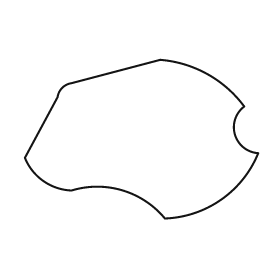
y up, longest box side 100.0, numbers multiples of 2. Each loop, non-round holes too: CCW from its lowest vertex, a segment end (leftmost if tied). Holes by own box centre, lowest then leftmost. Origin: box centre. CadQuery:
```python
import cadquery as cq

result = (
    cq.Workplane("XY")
    .moveTo(10.0, -34.0)
    .threePointArc((34.0, -26.0), (50.0, -6.0))
    .threePointArc((40.0, 2.0), (44.0, 14.0))
    .threePointArc((28.0, 28.0), (8.0, 34.0))
    .lineTo(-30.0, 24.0)
    .threePointArc((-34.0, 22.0), (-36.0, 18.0))
    .lineTo(-50.0, -8.0)
    .threePointArc((-42.0, -18.0), (-30.0, -22.0))
    .threePointArc((-8.0, -22.0), (10.0, -34.0))
    .close()
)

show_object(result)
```